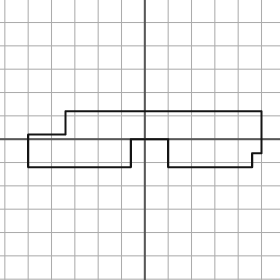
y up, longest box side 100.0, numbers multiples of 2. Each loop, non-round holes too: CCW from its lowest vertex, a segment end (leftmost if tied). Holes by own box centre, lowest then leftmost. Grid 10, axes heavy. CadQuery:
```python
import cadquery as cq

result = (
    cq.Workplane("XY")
    .moveTo(-50.0, -12.0)
    .lineTo(-6.0, -12.0)
    .lineTo(-6.0, 0.0)
    .lineTo(10.0, 0.0)
    .lineTo(10.0, -12.0)
    .lineTo(46.0, -12.0)
    .lineTo(46.0, -6.0)
    .lineTo(50.0, -6.0)
    .lineTo(50.0, 12.0)
    .lineTo(-34.0, 12.0)
    .lineTo(-34.0, 2.0)
    .lineTo(-50.0, 2.0)
    .close()
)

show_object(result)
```